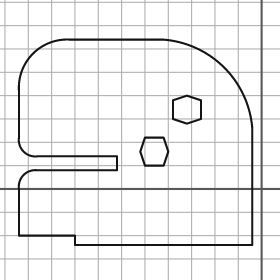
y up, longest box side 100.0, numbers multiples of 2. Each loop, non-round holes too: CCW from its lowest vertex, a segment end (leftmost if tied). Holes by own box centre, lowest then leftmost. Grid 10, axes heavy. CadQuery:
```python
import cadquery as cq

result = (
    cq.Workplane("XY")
    .moveTo(-80.0, -24.0)
    .lineTo(-4.0, -24.0)
    .lineTo(-4.0, 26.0)
    .threePointArc((-16.0, 52.0), (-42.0, 64.0))
    .lineTo(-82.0, 64.0)
    .threePointArc((-98.0, 58.0), (-104.0, 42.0))
    .lineTo(-104.0, 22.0)
    .threePointArc((-102.0, 16.0), (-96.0, 14.0))
    .lineTo(-62.0, 14.0)
    .lineTo(-62.0, 8.0)
    .lineTo(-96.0, 8.0)
    .threePointArc((-102.0, 6.0), (-104.0, 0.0))
    .lineTo(-104.0, -20.0)
    .lineTo(-80.0, -20.0)
    .close()
    .moveTo(-50.0, 10.0)
    .lineTo(-42.0, 10.0)
    .lineTo(-40.0, 16.0)
    .lineTo(-42.0, 22.0)
    .lineTo(-50.0, 22.0)
    .lineTo(-52.0, 16.0)
    .close()
    .moveTo(-32.0, 28.0)
    .lineTo(-26.0, 30.0)
    .lineTo(-26.0, 38.0)
    .lineTo(-32.0, 40.0)
    .lineTo(-38.0, 38.0)
    .lineTo(-38.0, 30.0)
    .close()
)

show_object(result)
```